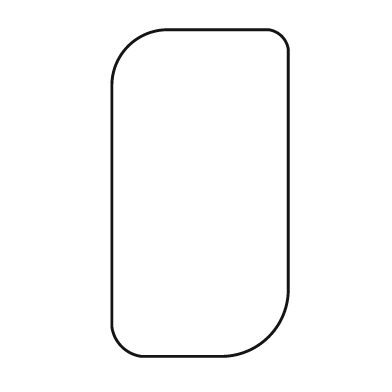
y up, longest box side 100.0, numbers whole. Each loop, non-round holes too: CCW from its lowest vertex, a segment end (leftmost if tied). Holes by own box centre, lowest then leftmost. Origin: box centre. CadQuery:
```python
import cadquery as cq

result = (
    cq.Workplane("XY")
    .moveTo(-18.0, -50.0)
    .lineTo(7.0, -50.0)
    .threePointArc((21.0, -44.0), (27.0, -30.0))
    .lineTo(27.0, 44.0)
    .threePointArc((25.0, 48.0), (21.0, 50.0))
    .lineTo(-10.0, 50.0)
    .threePointArc((-22.0, 45.0), (-27.0, 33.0))
    .lineTo(-27.0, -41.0)
    .threePointArc((-24.0, -47.0), (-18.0, -50.0))
    .close()
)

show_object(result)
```